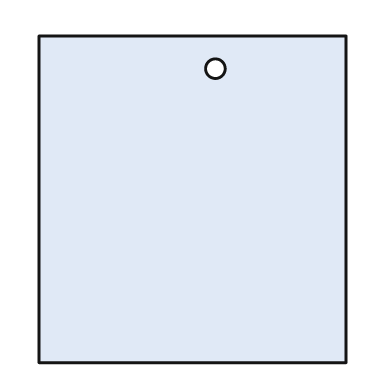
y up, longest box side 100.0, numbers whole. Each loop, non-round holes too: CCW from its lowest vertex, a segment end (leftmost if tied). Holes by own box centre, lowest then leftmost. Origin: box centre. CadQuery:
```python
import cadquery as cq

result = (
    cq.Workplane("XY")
    .moveTo(-47.0, -50.0)
    .lineTo(47.0, -50.0)
    .lineTo(47.0, 50.0)
    .lineTo(-47.0, 50.0)
    .close()
    .moveTo(7.0, 40.0)
    .circle(3.0)
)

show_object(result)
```